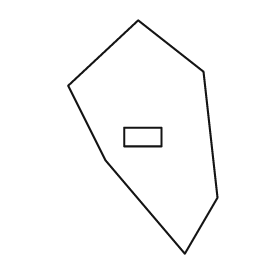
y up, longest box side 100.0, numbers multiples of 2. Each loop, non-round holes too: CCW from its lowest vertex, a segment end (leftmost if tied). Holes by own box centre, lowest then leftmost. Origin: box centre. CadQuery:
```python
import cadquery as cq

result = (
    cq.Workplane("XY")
    .moveTo(18.0, -50.0)
    .lineTo(32.0, -26.0)
    .lineTo(26.0, 28.0)
    .lineTo(-2.0, 50.0)
    .lineTo(-32.0, 22.0)
    .lineTo(-16.0, -10.0)
    .close()
    .moveTo(-8.0, -4.0)
    .lineTo(8.0, -4.0)
    .lineTo(8.0, 4.0)
    .lineTo(-8.0, 4.0)
    .close()
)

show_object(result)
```